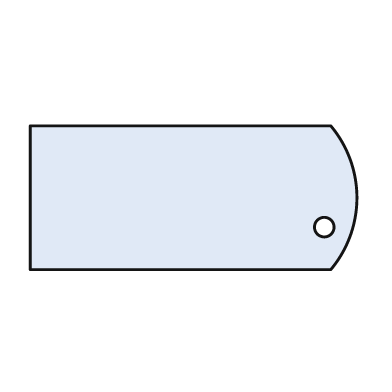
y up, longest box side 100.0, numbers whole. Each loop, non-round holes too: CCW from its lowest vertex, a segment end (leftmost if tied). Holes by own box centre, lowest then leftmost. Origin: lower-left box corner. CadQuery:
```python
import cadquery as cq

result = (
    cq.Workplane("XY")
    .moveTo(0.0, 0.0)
    .lineTo(92.0, 0.0)
    .threePointArc((100.0, 22.0), (92.0, 44.0))
    .lineTo(0.0, 44.0)
    .close()
    .moveTo(90.0, 13.0)
    .circle(3.0)
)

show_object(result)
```